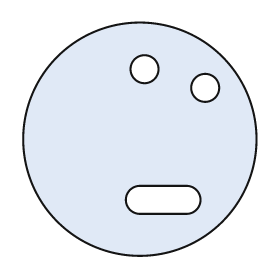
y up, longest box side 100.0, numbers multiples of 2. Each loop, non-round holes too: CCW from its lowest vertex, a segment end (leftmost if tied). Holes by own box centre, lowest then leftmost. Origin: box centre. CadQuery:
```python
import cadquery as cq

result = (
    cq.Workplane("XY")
    .moveTo(0.0, 0.0)
    .circle(50.0)
    .moveTo(0.0, -32.0)
    .lineTo(20.0, -32.0)
    .threePointArc((26.0, -26.0), (20.0, -20.0))
    .lineTo(0.0, -20.0)
    .threePointArc((-6.0, -26.0), (0.0, -32.0))
    .close()
    .moveTo(28.0, 22.0)
    .circle(6.0)
    .moveTo(2.0, 30.0)
    .circle(6.0)
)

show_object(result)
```